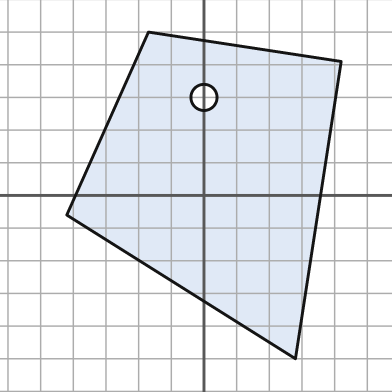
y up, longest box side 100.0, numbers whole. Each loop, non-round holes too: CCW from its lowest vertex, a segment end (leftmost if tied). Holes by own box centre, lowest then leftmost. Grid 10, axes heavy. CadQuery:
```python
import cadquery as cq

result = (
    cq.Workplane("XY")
    .moveTo(28.0, -50.0)
    .lineTo(42.0, 41.0)
    .lineTo(-17.0, 50.0)
    .lineTo(-42.0, -6.0)
    .close()
    .moveTo(0.0, 30.0)
    .circle(4.0)
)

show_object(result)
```